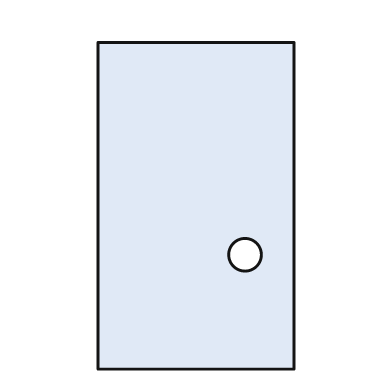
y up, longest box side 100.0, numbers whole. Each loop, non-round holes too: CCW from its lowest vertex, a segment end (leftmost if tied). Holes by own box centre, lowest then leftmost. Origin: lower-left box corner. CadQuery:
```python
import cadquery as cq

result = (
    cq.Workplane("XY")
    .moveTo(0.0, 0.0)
    .lineTo(60.0, 0.0)
    .lineTo(60.0, 100.0)
    .lineTo(0.0, 100.0)
    .close()
    .moveTo(45.0, 35.0)
    .circle(5.0)
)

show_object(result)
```